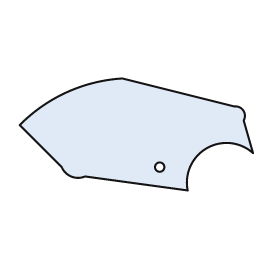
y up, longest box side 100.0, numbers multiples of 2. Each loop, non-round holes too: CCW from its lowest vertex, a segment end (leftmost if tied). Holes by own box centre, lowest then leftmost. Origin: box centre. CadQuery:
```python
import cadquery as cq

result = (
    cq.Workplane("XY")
    .moveTo(22.0, -24.0)
    .threePointArc((30.0, -6.0), (50.0, -8.0))
    .lineTo(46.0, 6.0)
    .threePointArc((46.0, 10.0), (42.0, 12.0))
    .lineTo(-6.0, 24.0)
    .threePointArc((-30.0, 18.0), (-50.0, 4.0))
    .lineTo(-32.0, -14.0)
    .threePointArc((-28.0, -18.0), (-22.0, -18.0))
    .close()
    .moveTo(10.0, -14.0)
    .circle(2.0)
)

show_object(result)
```